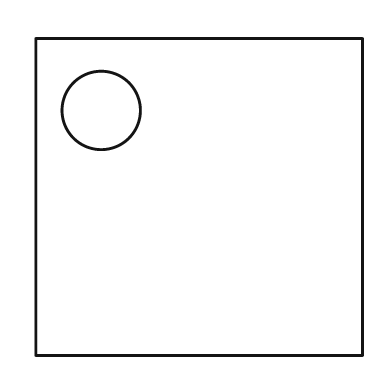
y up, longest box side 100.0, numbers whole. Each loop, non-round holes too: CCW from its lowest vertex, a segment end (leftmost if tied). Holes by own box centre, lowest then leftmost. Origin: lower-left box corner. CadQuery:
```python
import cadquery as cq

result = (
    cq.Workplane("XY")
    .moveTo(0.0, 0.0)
    .lineTo(100.0, 0.0)
    .lineTo(100.0, 97.0)
    .lineTo(0.0, 97.0)
    .close()
    .moveTo(20.0, 75.0)
    .circle(12.0)
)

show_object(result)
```